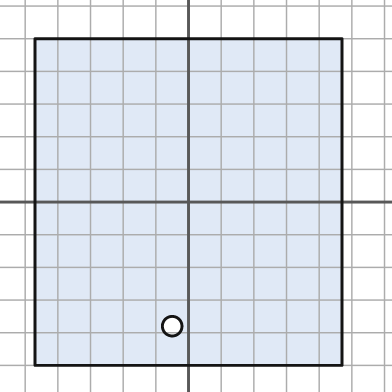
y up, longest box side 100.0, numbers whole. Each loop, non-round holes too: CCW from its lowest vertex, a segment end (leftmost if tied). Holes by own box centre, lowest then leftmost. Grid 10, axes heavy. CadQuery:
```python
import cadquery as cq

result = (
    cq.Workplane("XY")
    .moveTo(-47.0, -50.0)
    .lineTo(47.0, -50.0)
    .lineTo(47.0, 50.0)
    .lineTo(-47.0, 50.0)
    .close()
    .moveTo(-5.0, -38.0)
    .circle(3.0)
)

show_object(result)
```